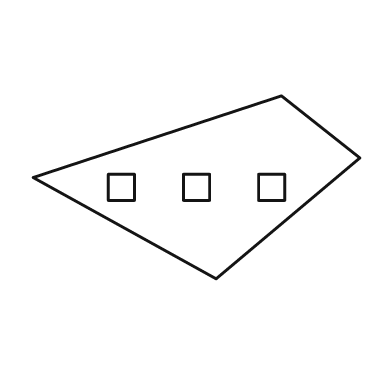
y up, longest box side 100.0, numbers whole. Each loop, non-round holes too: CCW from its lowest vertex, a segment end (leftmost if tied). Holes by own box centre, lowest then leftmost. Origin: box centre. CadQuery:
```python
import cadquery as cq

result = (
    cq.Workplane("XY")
    .moveTo(6.0, -28.0)
    .lineTo(50.0, 9.0)
    .lineTo(26.0, 28.0)
    .lineTo(-50.0, 3.0)
    .close()
    .moveTo(-27.0, -4.0)
    .lineTo(-19.0, -4.0)
    .lineTo(-19.0, 4.0)
    .lineTo(-27.0, 4.0)
    .close()
    .moveTo(-4.0, -4.0)
    .lineTo(4.0, -4.0)
    .lineTo(4.0, 4.0)
    .lineTo(-4.0, 4.0)
    .close()
    .moveTo(19.0, -4.0)
    .lineTo(27.0, -4.0)
    .lineTo(27.0, 4.0)
    .lineTo(19.0, 4.0)
    .close()
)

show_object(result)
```